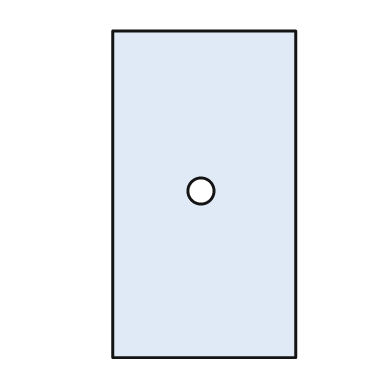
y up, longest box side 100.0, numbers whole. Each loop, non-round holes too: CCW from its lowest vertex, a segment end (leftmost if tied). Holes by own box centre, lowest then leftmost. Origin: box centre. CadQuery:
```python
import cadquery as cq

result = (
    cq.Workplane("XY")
    .moveTo(-28.0, -50.0)
    .lineTo(28.0, -50.0)
    .lineTo(28.0, 50.0)
    .lineTo(-28.0, 50.0)
    .close()
    .moveTo(-1.0, 1.0)
    .circle(4.0)
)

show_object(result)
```